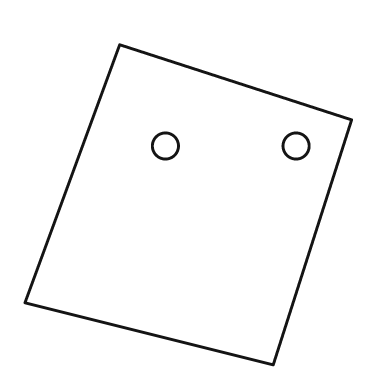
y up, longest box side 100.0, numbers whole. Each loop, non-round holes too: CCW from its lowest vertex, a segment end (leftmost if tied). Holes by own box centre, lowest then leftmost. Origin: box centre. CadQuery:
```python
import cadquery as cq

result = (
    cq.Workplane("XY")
    .moveTo(26.0, -49.0)
    .lineTo(50.0, 26.0)
    .lineTo(-21.0, 49.0)
    .lineTo(-50.0, -30.0)
    .close()
    .moveTo(-7.0, 18.0)
    .circle(4.0)
    .moveTo(33.0, 18.0)
    .circle(4.0)
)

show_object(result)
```